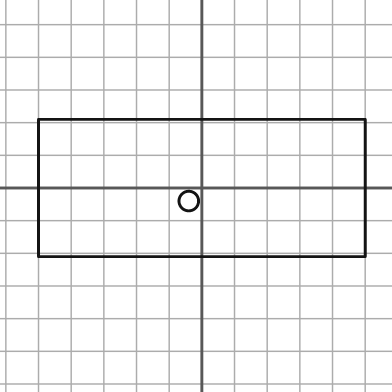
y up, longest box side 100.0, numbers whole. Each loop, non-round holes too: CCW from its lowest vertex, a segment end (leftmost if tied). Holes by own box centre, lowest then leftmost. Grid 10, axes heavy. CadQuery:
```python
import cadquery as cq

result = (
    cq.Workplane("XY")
    .moveTo(-50.0, -21.0)
    .lineTo(50.0, -21.0)
    .lineTo(50.0, 21.0)
    .lineTo(-50.0, 21.0)
    .close()
    .moveTo(-4.0, -4.0)
    .circle(3.0)
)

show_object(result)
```